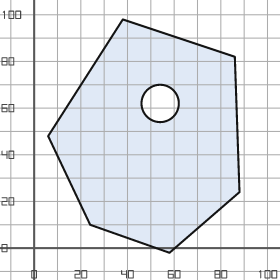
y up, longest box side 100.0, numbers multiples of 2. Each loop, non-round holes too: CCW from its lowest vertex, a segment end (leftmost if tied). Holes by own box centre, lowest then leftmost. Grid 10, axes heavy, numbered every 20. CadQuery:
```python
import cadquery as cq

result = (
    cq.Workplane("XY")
    .moveTo(58.0, -2.0)
    .lineTo(88.0, 24.0)
    .lineTo(86.0, 82.0)
    .lineTo(38.0, 98.0)
    .lineTo(6.0, 48.0)
    .lineTo(24.0, 10.0)
    .close()
    .moveTo(54.0, 62.0)
    .circle(8.0)
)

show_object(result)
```